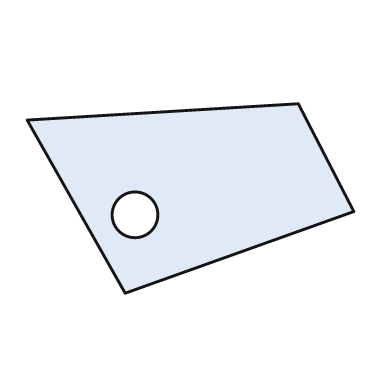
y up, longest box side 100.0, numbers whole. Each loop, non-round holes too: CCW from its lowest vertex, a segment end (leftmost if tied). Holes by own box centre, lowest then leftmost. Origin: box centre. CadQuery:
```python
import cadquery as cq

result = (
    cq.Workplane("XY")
    .moveTo(-20.0, -29.0)
    .lineTo(50.0, -4.0)
    .lineTo(33.0, 29.0)
    .lineTo(-50.0, 24.0)
    .close()
    .moveTo(-17.0, -5.0)
    .circle(7.0)
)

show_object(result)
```